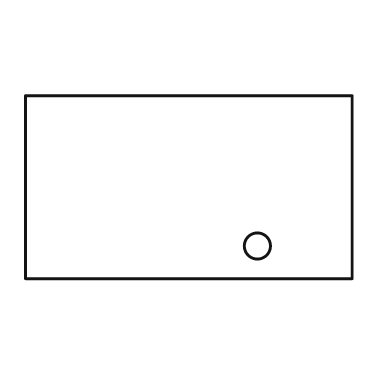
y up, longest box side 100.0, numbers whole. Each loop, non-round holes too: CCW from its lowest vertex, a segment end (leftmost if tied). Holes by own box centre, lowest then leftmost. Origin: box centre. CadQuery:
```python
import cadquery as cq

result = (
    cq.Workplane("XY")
    .moveTo(-50.0, -28.0)
    .lineTo(50.0, -28.0)
    .lineTo(50.0, 28.0)
    .lineTo(-50.0, 28.0)
    .close()
    .moveTo(21.0, -18.0)
    .circle(4.0)
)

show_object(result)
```